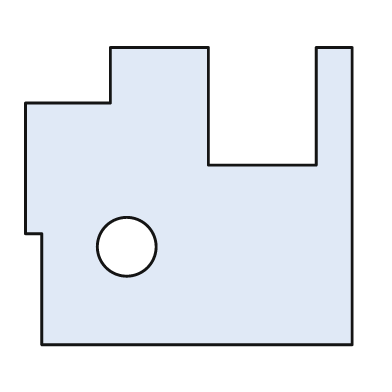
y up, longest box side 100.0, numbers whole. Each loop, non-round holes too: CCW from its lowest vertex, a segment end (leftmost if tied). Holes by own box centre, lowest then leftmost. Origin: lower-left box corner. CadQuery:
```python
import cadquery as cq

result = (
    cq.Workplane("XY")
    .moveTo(5.0, 0.0)
    .lineTo(100.0, 0.0)
    .lineTo(100.0, 91.0)
    .lineTo(89.0, 91.0)
    .lineTo(89.0, 55.0)
    .lineTo(56.0, 55.0)
    .lineTo(56.0, 91.0)
    .lineTo(26.0, 91.0)
    .lineTo(26.0, 74.0)
    .lineTo(0.0, 74.0)
    .lineTo(0.0, 34.0)
    .lineTo(5.0, 34.0)
    .close()
    .moveTo(31.0, 30.0)
    .circle(9.0)
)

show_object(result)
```